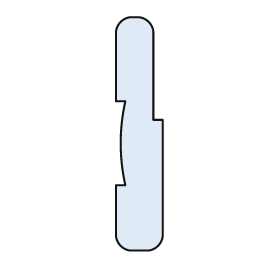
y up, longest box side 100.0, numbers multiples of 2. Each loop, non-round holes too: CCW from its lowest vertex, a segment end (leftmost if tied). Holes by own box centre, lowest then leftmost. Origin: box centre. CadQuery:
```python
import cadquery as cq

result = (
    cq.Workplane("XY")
    .moveTo(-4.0, -50.0)
    .lineTo(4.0, -50.0)
    .threePointArc((8.0, -48.0), (10.0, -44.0))
    .lineTo(10.0, 6.0)
    .lineTo(6.0, 6.0)
    .lineTo(6.0, 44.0)
    .threePointArc((4.0, 48.0), (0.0, 50.0))
    .lineTo(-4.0, 50.0)
    .threePointArc((-8.0, 48.0), (-10.0, 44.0))
    .lineTo(-10.0, 14.0)
    .lineTo(-6.0, 14.0)
    .threePointArc((-8.0, -4.0), (-6.0, -22.0))
    .lineTo(-10.0, -22.0)
    .lineTo(-10.0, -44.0)
    .threePointArc((-8.0, -48.0), (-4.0, -50.0))
    .close()
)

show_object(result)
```